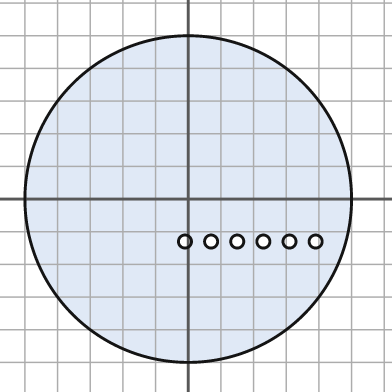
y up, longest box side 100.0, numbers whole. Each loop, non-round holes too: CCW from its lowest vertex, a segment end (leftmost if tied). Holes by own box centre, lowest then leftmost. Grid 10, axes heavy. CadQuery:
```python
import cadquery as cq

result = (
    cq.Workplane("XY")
    .moveTo(0.0, 0.0)
    .circle(50.0)
    .moveTo(-1.0, -13.0)
    .circle(2.0)
    .moveTo(7.0, -13.0)
    .circle(2.0)
    .moveTo(15.0, -13.0)
    .circle(2.0)
    .moveTo(23.0, -13.0)
    .circle(2.0)
    .moveTo(31.0, -13.0)
    .circle(2.0)
    .moveTo(39.0, -13.0)
    .circle(2.0)
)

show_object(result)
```